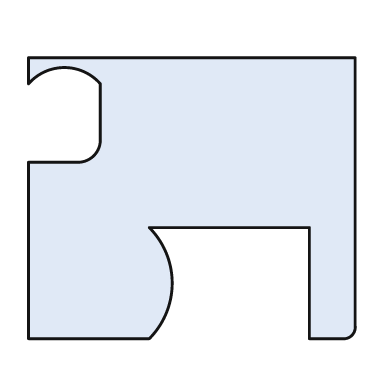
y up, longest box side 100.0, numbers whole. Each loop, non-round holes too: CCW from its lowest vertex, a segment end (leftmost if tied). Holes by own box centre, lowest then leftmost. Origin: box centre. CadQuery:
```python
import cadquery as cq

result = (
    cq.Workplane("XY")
    .moveTo(-50.0, -43.0)
    .lineTo(-13.0, -43.0)
    .threePointArc((-6.0, -26.0), (-13.0, -9.0))
    .lineTo(36.0, -9.0)
    .lineTo(36.0, -43.0)
    .lineTo(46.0, -43.0)
    .threePointArc((49.0, -42.0), (50.0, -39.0))
    .lineTo(50.0, 43.0)
    .lineTo(-50.0, 43.0)
    .lineTo(-50.0, 35.0)
    .threePointArc((-39.0, 40.0), (-28.0, 35.0))
    .lineTo(-28.0, 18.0)
    .threePointArc((-30.0, 13.0), (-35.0, 11.0))
    .lineTo(-50.0, 11.0)
    .close()
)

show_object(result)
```